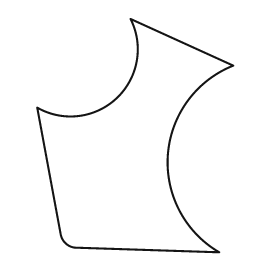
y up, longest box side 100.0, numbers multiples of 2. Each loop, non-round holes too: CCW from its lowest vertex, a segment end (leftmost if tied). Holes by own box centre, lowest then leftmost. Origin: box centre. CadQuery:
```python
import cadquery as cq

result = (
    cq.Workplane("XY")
    .moveTo(36.0, -50.0)
    .threePointArc((14.0, -8.0), (42.0, 30.0))
    .lineTo(-2.0, 50.0)
    .threePointArc((-8.0, 16.0), (-42.0, 12.0))
    .lineTo(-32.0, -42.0)
    .threePointArc((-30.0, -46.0), (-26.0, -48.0))
    .close()
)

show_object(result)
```